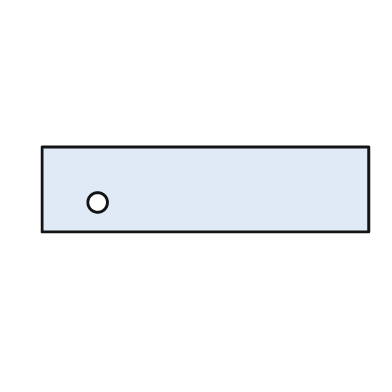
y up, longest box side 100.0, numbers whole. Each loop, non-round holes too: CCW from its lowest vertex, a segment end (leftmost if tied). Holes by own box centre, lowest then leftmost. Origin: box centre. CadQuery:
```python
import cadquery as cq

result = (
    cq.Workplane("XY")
    .moveTo(-50.0, -13.0)
    .lineTo(50.0, -13.0)
    .lineTo(50.0, 13.0)
    .lineTo(-50.0, 13.0)
    .close()
    .moveTo(-33.0, -4.0)
    .circle(3.0)
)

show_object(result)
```